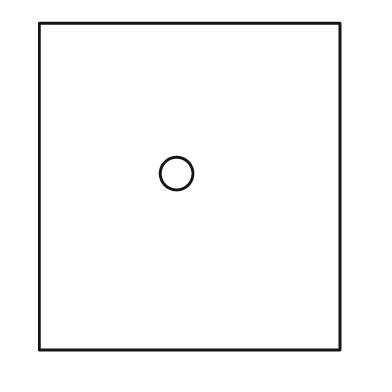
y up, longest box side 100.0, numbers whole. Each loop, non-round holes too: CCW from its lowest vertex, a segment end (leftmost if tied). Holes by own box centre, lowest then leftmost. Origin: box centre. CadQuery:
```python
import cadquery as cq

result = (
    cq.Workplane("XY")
    .moveTo(-46.0, -50.0)
    .lineTo(46.0, -50.0)
    .lineTo(46.0, 50.0)
    .lineTo(-46.0, 50.0)
    .close()
    .moveTo(-4.0, 4.0)
    .circle(5.0)
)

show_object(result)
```